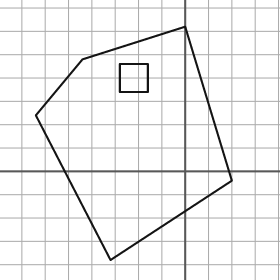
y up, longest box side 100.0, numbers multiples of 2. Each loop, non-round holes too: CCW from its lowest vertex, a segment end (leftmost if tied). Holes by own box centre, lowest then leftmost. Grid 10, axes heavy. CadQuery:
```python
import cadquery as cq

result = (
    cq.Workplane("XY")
    .moveTo(-32.0, -38.0)
    .lineTo(20.0, -4.0)
    .lineTo(0.0, 62.0)
    .lineTo(-44.0, 48.0)
    .lineTo(-64.0, 24.0)
    .close()
    .moveTo(-28.0, 34.0)
    .lineTo(-16.0, 34.0)
    .lineTo(-16.0, 46.0)
    .lineTo(-28.0, 46.0)
    .close()
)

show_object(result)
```